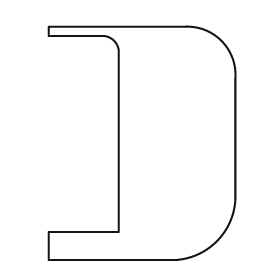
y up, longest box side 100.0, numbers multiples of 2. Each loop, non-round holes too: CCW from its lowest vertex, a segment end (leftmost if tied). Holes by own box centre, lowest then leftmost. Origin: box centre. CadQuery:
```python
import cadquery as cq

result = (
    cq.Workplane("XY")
    .moveTo(-40.0, -50.0)
    .lineTo(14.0, -50.0)
    .threePointArc((32.0, -42.0), (40.0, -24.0))
    .lineTo(40.0, 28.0)
    .threePointArc((34.0, 44.0), (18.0, 50.0))
    .lineTo(-40.0, 50.0)
    .lineTo(-40.0, 46.0)
    .lineTo(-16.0, 46.0)
    .threePointArc((-12.0, 44.0), (-10.0, 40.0))
    .lineTo(-10.0, -38.0)
    .lineTo(-40.0, -38.0)
    .close()
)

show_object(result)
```